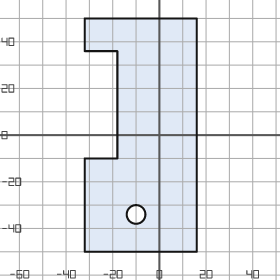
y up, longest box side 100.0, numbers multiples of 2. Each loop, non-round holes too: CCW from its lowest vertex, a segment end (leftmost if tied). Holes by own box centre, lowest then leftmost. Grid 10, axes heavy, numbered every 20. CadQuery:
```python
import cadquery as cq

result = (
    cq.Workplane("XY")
    .moveTo(-32.0, -50.0)
    .lineTo(16.0, -50.0)
    .lineTo(16.0, 50.0)
    .lineTo(-32.0, 50.0)
    .lineTo(-32.0, 36.0)
    .lineTo(-18.0, 36.0)
    .lineTo(-18.0, -10.0)
    .lineTo(-32.0, -10.0)
    .close()
    .moveTo(-10.0, -34.0)
    .circle(4.0)
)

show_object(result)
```